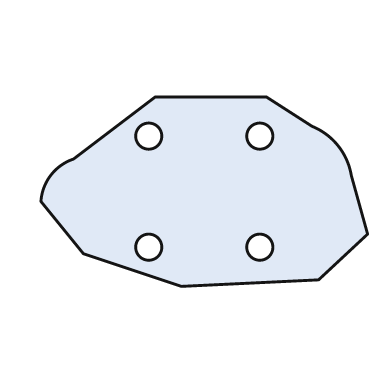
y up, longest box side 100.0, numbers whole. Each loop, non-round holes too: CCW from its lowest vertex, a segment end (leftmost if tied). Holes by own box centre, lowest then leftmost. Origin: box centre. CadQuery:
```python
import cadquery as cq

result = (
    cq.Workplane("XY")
    .moveTo(-7.0, -29.0)
    .lineTo(35.0, -27.0)
    .lineTo(50.0, -13.0)
    .lineTo(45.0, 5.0)
    .threePointArc((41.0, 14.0), (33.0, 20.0))
    .lineTo(19.0, 29.0)
    .lineTo(-15.0, 29.0)
    .lineTo(-40.0, 10.0)
    .threePointArc((-47.0, 5.0), (-50.0, -3.0))
    .lineTo(-37.0, -19.0)
    .close()
    .moveTo(-17.0, -17.0)
    .circle(4.0)
    .moveTo(17.0, -17.0)
    .circle(4.0)
    .moveTo(-17.0, 17.0)
    .circle(4.0)
    .moveTo(17.0, 17.0)
    .circle(4.0)
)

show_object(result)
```